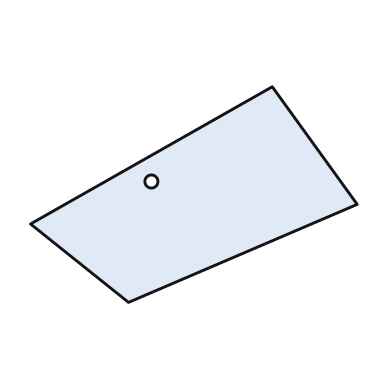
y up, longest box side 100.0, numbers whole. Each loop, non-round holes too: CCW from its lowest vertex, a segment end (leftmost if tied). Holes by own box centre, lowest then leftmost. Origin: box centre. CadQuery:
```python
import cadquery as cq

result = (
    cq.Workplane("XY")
    .moveTo(-20.0, -33.0)
    .lineTo(50.0, -3.0)
    .lineTo(24.0, 33.0)
    .lineTo(-50.0, -9.0)
    .close()
    .moveTo(-13.0, 4.0)
    .circle(2.0)
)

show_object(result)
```